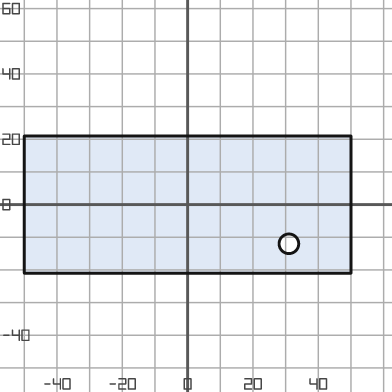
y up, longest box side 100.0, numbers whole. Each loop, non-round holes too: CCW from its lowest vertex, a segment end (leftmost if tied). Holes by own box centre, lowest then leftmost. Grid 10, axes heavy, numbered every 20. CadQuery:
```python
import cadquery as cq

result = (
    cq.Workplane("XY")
    .moveTo(-50.0, -21.0)
    .lineTo(50.0, -21.0)
    .lineTo(50.0, 21.0)
    .lineTo(-50.0, 21.0)
    .close()
    .moveTo(31.0, -12.0)
    .circle(3.0)
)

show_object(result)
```